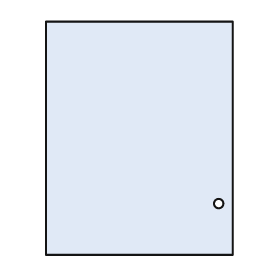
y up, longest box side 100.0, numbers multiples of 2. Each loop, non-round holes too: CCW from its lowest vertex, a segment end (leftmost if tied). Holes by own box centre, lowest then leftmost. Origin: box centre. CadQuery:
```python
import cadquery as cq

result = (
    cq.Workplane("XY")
    .moveTo(-40.0, -50.0)
    .lineTo(40.0, -50.0)
    .lineTo(40.0, 50.0)
    .lineTo(-40.0, 50.0)
    .close()
    .moveTo(34.0, -28.0)
    .circle(2.0)
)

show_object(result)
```